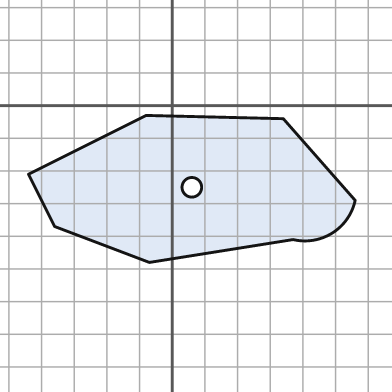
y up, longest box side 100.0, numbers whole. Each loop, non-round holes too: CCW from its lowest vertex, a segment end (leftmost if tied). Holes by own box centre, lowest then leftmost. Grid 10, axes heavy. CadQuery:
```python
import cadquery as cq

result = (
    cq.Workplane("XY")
    .moveTo(-7.0, -48.0)
    .lineTo(37.0, -41.0)
    .threePointArc((49.0, -39.0), (56.0, -29.0))
    .lineTo(34.0, -4.0)
    .lineTo(-8.0, -3.0)
    .lineTo(-44.0, -21.0)
    .lineTo(-36.0, -37.0)
    .close()
    .moveTo(6.0, -25.0)
    .circle(3.0)
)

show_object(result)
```